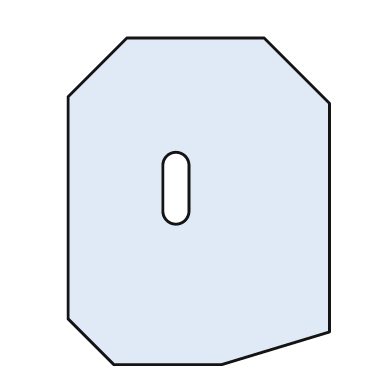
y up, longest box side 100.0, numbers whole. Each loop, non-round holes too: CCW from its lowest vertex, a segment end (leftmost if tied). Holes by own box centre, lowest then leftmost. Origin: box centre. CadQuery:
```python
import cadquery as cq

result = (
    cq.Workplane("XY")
    .moveTo(-26.0, -50.0)
    .lineTo(7.0, -50.0)
    .lineTo(40.0, -40.0)
    .lineTo(40.0, 30.0)
    .lineTo(20.0, 50.0)
    .lineTo(-22.0, 50.0)
    .lineTo(-40.0, 32.0)
    .lineTo(-40.0, -36.0)
    .close()
    .moveTo(-11.0, -3.0)
    .threePointArc((-7.0, -7.0), (-3.0, -3.0))
    .lineTo(-3.0, 11.0)
    .threePointArc((-7.0, 15.0), (-11.0, 11.0))
    .close()
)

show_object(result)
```